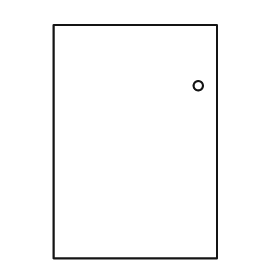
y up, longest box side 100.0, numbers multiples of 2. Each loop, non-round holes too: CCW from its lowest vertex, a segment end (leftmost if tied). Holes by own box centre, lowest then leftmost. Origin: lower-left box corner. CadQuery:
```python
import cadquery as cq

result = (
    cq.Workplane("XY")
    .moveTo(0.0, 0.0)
    .lineTo(70.0, 0.0)
    .lineTo(70.0, 100.0)
    .lineTo(0.0, 100.0)
    .close()
    .moveTo(62.0, 74.0)
    .circle(2.0)
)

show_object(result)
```